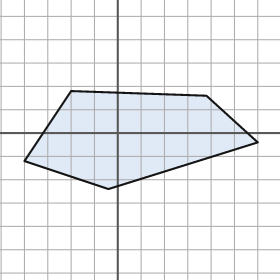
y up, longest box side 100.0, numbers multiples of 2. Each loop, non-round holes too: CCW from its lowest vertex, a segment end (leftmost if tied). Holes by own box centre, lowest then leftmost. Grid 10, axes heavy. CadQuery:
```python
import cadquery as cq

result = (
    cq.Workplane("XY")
    .moveTo(-4.0, -24.0)
    .lineTo(60.0, -4.0)
    .lineTo(38.0, 16.0)
    .lineTo(-20.0, 18.0)
    .lineTo(-40.0, -12.0)
    .close()
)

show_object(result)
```